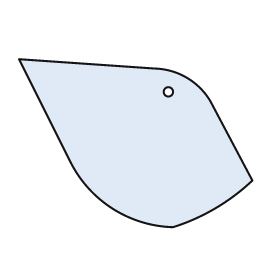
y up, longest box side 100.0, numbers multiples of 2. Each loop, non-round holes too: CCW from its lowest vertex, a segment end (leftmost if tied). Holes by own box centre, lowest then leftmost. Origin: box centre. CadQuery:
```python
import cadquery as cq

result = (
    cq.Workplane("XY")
    .moveTo(16.0, -36.0)
    .threePointArc((34.0, -28.0), (50.0, -16.0))
    .lineTo(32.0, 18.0)
    .threePointArc((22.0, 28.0), (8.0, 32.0))
    .lineTo(-50.0, 36.0)
    .lineTo(-28.0, -8.0)
    .threePointArc((-10.0, -28.0), (16.0, -36.0))
    .close()
    .moveTo(14.0, 22.0)
    .circle(2.0)
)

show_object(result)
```